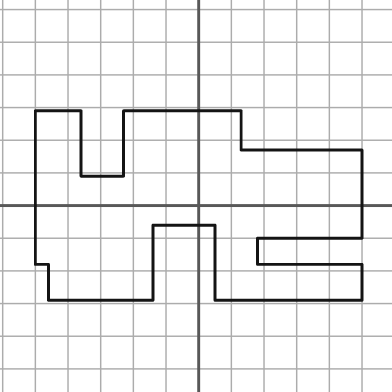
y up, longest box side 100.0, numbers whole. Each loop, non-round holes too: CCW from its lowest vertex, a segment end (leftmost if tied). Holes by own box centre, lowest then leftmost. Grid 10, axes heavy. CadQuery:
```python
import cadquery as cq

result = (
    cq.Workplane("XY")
    .moveTo(-46.0, -29.0)
    .lineTo(-14.0, -29.0)
    .lineTo(-14.0, -6.0)
    .lineTo(5.0, -6.0)
    .lineTo(5.0, -29.0)
    .lineTo(50.0, -29.0)
    .lineTo(50.0, -18.0)
    .lineTo(18.0, -18.0)
    .lineTo(18.0, -10.0)
    .lineTo(50.0, -10.0)
    .lineTo(50.0, 17.0)
    .lineTo(13.0, 17.0)
    .lineTo(13.0, 29.0)
    .lineTo(-23.0, 29.0)
    .lineTo(-23.0, 9.0)
    .lineTo(-36.0, 9.0)
    .lineTo(-36.0, 29.0)
    .lineTo(-50.0, 29.0)
    .lineTo(-50.0, -18.0)
    .lineTo(-46.0, -18.0)
    .close()
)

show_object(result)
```